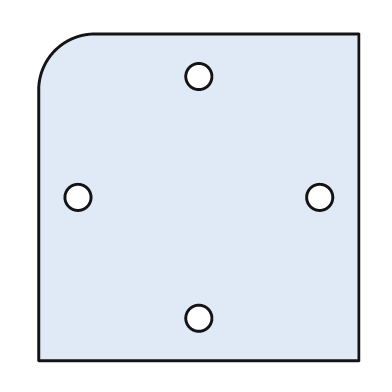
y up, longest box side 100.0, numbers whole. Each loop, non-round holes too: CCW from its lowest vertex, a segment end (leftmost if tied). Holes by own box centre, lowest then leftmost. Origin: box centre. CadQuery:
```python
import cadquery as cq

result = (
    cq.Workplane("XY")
    .moveTo(-49.0, -50.0)
    .lineTo(49.0, -50.0)
    .lineTo(49.0, 50.0)
    .lineTo(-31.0, 50.0)
    .threePointArc((-44.0, 45.0), (-49.0, 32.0))
    .close()
    .moveTo(0.0, -37.0)
    .circle(4.0)
    .moveTo(-37.0, 0.0)
    .circle(4.0)
    .moveTo(37.0, 0.0)
    .circle(4.0)
    .moveTo(0.0, 37.0)
    .circle(4.0)
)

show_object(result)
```